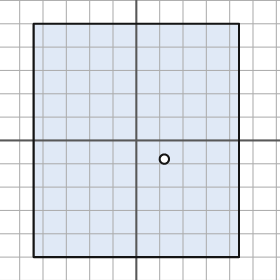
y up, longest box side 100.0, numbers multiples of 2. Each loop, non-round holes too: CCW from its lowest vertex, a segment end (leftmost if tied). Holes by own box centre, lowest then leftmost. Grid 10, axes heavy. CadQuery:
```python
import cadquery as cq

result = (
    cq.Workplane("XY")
    .moveTo(-44.0, -50.0)
    .lineTo(44.0, -50.0)
    .lineTo(44.0, 50.0)
    .lineTo(-44.0, 50.0)
    .close()
    .moveTo(12.0, -8.0)
    .circle(2.0)
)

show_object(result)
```